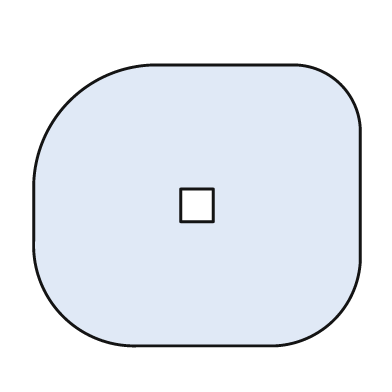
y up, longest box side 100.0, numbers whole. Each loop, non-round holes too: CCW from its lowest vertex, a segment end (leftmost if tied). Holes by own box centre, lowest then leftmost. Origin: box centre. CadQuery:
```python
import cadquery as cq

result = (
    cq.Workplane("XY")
    .moveTo(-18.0, -43.0)
    .lineTo(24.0, -43.0)
    .threePointArc((42.0, -35.0), (50.0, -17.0))
    .lineTo(50.0, 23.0)
    .threePointArc((44.0, 37.0), (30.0, 43.0))
    .lineTo(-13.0, 43.0)
    .threePointArc((-39.0, 32.0), (-50.0, 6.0))
    .lineTo(-50.0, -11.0)
    .threePointArc((-41.0, -34.0), (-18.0, -43.0))
    .close()
    .moveTo(-5.0, -5.0)
    .lineTo(5.0, -5.0)
    .lineTo(5.0, 5.0)
    .lineTo(-5.0, 5.0)
    .close()
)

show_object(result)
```